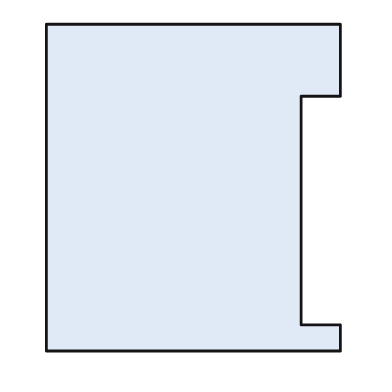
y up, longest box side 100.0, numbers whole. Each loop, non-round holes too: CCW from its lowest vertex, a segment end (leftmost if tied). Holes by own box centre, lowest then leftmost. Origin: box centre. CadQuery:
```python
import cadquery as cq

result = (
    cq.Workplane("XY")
    .moveTo(-45.0, -50.0)
    .lineTo(45.0, -50.0)
    .lineTo(45.0, -42.0)
    .lineTo(33.0, -42.0)
    .lineTo(33.0, 28.0)
    .lineTo(45.0, 28.0)
    .lineTo(45.0, 50.0)
    .lineTo(-45.0, 50.0)
    .close()
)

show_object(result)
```